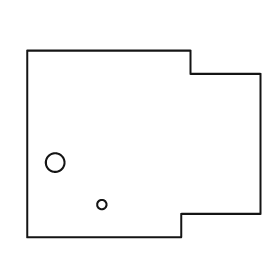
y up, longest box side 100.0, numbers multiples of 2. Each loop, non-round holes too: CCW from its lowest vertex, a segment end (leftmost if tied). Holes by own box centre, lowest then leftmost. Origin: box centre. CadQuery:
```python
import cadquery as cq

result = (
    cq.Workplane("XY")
    .moveTo(-50.0, -40.0)
    .lineTo(16.0, -40.0)
    .lineTo(16.0, -30.0)
    .lineTo(50.0, -30.0)
    .lineTo(50.0, 30.0)
    .lineTo(20.0, 30.0)
    .lineTo(20.0, 40.0)
    .lineTo(-50.0, 40.0)
    .close()
    .moveTo(-18.0, -26.0)
    .circle(2.0)
    .moveTo(-38.0, -8.0)
    .circle(4.0)
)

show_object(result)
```